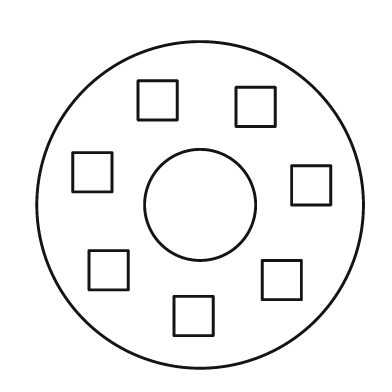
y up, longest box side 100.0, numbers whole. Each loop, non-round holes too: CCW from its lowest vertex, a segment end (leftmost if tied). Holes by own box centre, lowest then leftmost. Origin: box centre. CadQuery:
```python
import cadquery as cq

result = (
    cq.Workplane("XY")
    .moveTo(0.0, 0.0)
    .circle(50.0)
    .moveTo(-8.0, -40.0)
    .lineTo(4.0, -40.0)
    .lineTo(4.0, -28.0)
    .lineTo(-8.0, -28.0)
    .close()
    .moveTo(19.0, -29.0)
    .lineTo(31.0, -29.0)
    .lineTo(31.0, -17.0)
    .lineTo(19.0, -17.0)
    .close()
    .moveTo(-34.0, -26.0)
    .lineTo(-22.0, -26.0)
    .lineTo(-22.0, -14.0)
    .lineTo(-34.0, -14.0)
    .close()
    .moveTo(0.0, 0.0)
    .circle(17.0)
    .moveTo(28.0, 0.0)
    .lineTo(40.0, 0.0)
    .lineTo(40.0, 12.0)
    .lineTo(28.0, 12.0)
    .close()
    .moveTo(-39.0, 4.0)
    .lineTo(-27.0, 4.0)
    .lineTo(-27.0, 16.0)
    .lineTo(-39.0, 16.0)
    .close()
    .moveTo(11.0, 24.0)
    .lineTo(23.0, 24.0)
    .lineTo(23.0, 36.0)
    .lineTo(11.0, 36.0)
    .close()
    .moveTo(-19.0, 26.0)
    .lineTo(-7.0, 26.0)
    .lineTo(-7.0, 38.0)
    .lineTo(-19.0, 38.0)
    .close()
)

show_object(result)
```